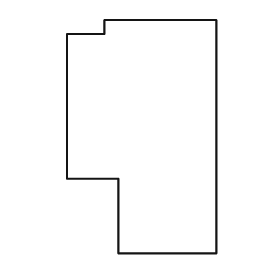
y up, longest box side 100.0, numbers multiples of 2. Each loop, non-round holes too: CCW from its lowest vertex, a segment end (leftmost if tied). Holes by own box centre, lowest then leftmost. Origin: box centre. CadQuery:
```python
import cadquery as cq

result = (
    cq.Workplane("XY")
    .moveTo(-10.0, -50.0)
    .lineTo(32.0, -50.0)
    .lineTo(32.0, 50.0)
    .lineTo(-16.0, 50.0)
    .lineTo(-16.0, 44.0)
    .lineTo(-32.0, 44.0)
    .lineTo(-32.0, -18.0)
    .lineTo(-10.0, -18.0)
    .close()
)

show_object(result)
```